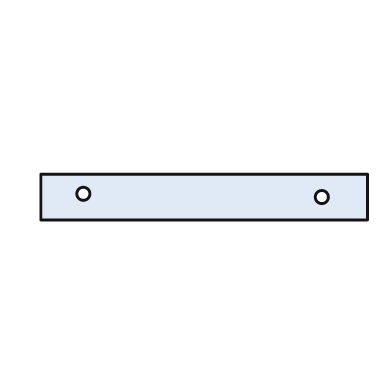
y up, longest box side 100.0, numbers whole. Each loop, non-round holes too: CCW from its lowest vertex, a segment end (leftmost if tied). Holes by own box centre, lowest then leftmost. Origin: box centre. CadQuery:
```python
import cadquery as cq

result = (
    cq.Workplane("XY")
    .moveTo(-50.0, -7.0)
    .lineTo(50.0, -7.0)
    .lineTo(50.0, 7.0)
    .lineTo(-50.0, 7.0)
    .close()
    .moveTo(36.0, 0.0)
    .circle(2.0)
    .moveTo(-37.0, 1.0)
    .circle(2.0)
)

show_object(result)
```